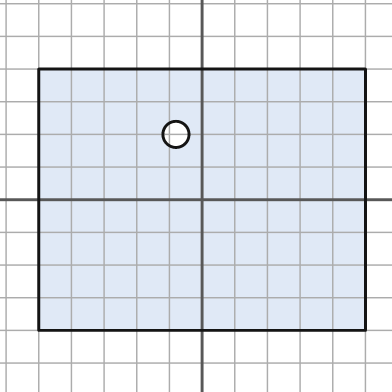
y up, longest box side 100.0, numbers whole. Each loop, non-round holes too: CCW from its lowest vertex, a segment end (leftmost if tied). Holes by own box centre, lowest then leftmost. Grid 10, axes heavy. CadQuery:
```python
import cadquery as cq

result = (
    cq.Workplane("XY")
    .moveTo(-50.0, -40.0)
    .lineTo(50.0, -40.0)
    .lineTo(50.0, 40.0)
    .lineTo(-50.0, 40.0)
    .close()
    .moveTo(-8.0, 20.0)
    .circle(4.0)
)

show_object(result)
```